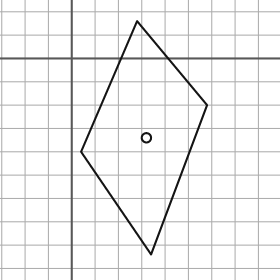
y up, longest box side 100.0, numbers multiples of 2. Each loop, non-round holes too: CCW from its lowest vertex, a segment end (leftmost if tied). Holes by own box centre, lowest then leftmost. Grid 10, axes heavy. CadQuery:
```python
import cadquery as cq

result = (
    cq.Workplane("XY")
    .moveTo(34.0, -84.0)
    .lineTo(58.0, -20.0)
    .lineTo(28.0, 16.0)
    .lineTo(4.0, -40.0)
    .close()
    .moveTo(32.0, -34.0)
    .circle(2.0)
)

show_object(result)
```